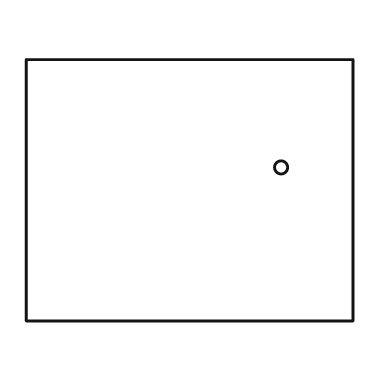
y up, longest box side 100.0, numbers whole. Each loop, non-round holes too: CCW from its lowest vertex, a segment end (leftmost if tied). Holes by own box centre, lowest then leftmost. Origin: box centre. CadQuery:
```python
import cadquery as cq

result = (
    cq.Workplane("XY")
    .moveTo(-50.0, -40.0)
    .lineTo(50.0, -40.0)
    .lineTo(50.0, 40.0)
    .lineTo(-50.0, 40.0)
    .close()
    .moveTo(28.0, 7.0)
    .circle(2.0)
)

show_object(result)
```